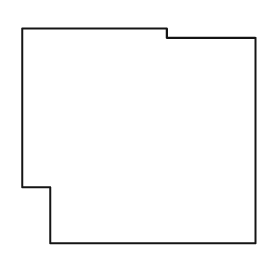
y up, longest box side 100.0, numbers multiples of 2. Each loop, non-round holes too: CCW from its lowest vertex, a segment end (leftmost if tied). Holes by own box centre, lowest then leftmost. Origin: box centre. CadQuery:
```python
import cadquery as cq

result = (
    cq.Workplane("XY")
    .moveTo(-38.0, -46.0)
    .lineTo(50.0, -46.0)
    .lineTo(50.0, 42.0)
    .lineTo(12.0, 42.0)
    .lineTo(12.0, 46.0)
    .lineTo(-50.0, 46.0)
    .lineTo(-50.0, -22.0)
    .lineTo(-38.0, -22.0)
    .close()
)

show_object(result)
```